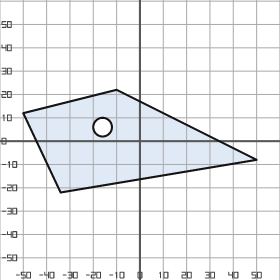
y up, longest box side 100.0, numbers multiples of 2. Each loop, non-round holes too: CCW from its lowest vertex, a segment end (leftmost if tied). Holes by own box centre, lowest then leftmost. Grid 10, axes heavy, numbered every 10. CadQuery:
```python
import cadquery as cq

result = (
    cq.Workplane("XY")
    .moveTo(-34.0, -22.0)
    .lineTo(50.0, -8.0)
    .lineTo(-10.0, 22.0)
    .lineTo(-50.0, 12.0)
    .close()
    .moveTo(-16.0, 6.0)
    .circle(4.0)
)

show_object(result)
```